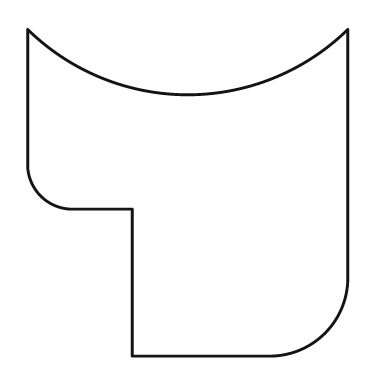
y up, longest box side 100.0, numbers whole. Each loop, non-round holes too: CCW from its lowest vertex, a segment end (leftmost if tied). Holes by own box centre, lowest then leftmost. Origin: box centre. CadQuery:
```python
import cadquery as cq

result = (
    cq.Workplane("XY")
    .moveTo(-17.0, -50.0)
    .lineTo(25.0, -50.0)
    .threePointArc((42.0, -43.0), (49.0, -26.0))
    .lineTo(49.0, 50.0)
    .threePointArc((0.0, 30.0), (-49.0, 50.0))
    .lineTo(-49.0, 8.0)
    .threePointArc((-45.0, -1.0), (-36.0, -5.0))
    .lineTo(-17.0, -5.0)
    .close()
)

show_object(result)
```